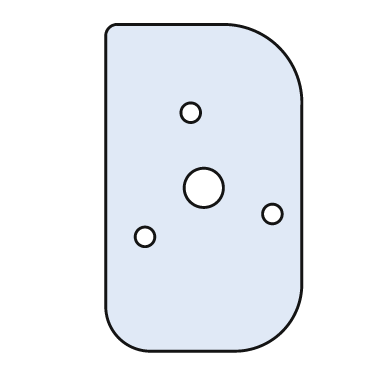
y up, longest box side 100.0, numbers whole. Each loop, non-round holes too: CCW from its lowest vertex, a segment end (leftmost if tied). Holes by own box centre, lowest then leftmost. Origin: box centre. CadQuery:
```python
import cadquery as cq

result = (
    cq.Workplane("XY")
    .moveTo(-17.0, -50.0)
    .lineTo(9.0, -50.0)
    .threePointArc((24.0, -44.0), (30.0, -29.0))
    .lineTo(30.0, 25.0)
    .threePointArc((23.0, 43.0), (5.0, 50.0))
    .lineTo(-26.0, 50.0)
    .threePointArc((-29.0, 49.0), (-30.0, 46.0))
    .lineTo(-30.0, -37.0)
    .threePointArc((-26.0, -46.0), (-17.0, -50.0))
    .close()
    .moveTo(-18.0, -15.0)
    .circle(3.0)
    .moveTo(21.0, -8.0)
    .circle(3.0)
    .moveTo(0.0, 0.0)
    .circle(6.0)
    .moveTo(-4.0, 23.0)
    .circle(3.0)
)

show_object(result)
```